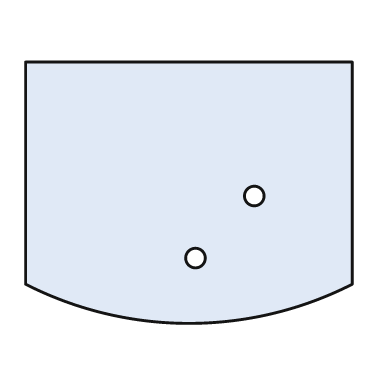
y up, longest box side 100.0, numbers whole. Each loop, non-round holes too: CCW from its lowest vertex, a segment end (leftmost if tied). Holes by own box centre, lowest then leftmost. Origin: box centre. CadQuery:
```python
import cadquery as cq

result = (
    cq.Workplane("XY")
    .moveTo(-50.0, -28.0)
    .threePointArc((0.0, -40.0), (50.0, -28.0))
    .lineTo(50.0, 40.0)
    .lineTo(-50.0, 40.0)
    .close()
    .moveTo(2.0, -20.0)
    .circle(3.0)
    .moveTo(20.0, -1.0)
    .circle(3.0)
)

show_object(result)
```